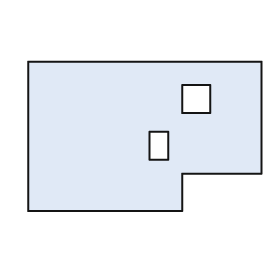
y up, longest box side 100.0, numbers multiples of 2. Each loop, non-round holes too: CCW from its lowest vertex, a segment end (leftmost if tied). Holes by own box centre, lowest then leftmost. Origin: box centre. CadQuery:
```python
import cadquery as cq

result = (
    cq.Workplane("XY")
    .moveTo(-50.0, -32.0)
    .lineTo(16.0, -32.0)
    .lineTo(16.0, -16.0)
    .lineTo(50.0, -16.0)
    .lineTo(50.0, 32.0)
    .lineTo(-50.0, 32.0)
    .close()
    .moveTo(2.0, -10.0)
    .lineTo(10.0, -10.0)
    .lineTo(10.0, 2.0)
    .lineTo(2.0, 2.0)
    .close()
    .moveTo(16.0, 10.0)
    .lineTo(28.0, 10.0)
    .lineTo(28.0, 22.0)
    .lineTo(16.0, 22.0)
    .close()
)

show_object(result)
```